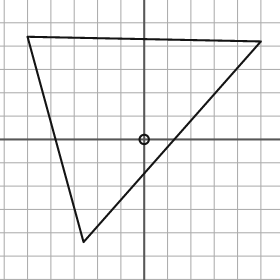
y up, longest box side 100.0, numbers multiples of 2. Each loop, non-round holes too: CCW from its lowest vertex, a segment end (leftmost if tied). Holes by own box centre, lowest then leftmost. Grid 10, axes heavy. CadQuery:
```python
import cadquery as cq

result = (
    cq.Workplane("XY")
    .moveTo(-26.0, -44.0)
    .lineTo(50.0, 42.0)
    .lineTo(-50.0, 44.0)
    .close()
    .moveTo(0.0, 0.0)
    .circle(2.0)
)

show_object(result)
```